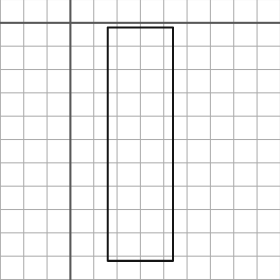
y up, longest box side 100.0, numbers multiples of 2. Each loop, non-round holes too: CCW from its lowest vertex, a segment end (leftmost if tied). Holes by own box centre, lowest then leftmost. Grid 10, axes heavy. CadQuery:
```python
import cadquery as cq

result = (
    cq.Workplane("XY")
    .moveTo(16.0, -102.0)
    .lineTo(44.0, -102.0)
    .lineTo(44.0, -2.0)
    .lineTo(16.0, -2.0)
    .close()
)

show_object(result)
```